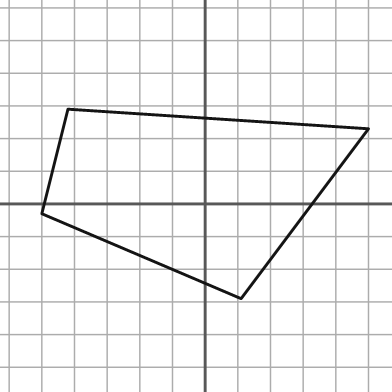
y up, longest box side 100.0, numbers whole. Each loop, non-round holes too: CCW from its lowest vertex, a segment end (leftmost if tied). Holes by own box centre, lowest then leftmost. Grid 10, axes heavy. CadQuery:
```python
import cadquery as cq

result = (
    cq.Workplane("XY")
    .moveTo(11.0, -29.0)
    .lineTo(50.0, 23.0)
    .lineTo(-42.0, 29.0)
    .lineTo(-50.0, -3.0)
    .close()
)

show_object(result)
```